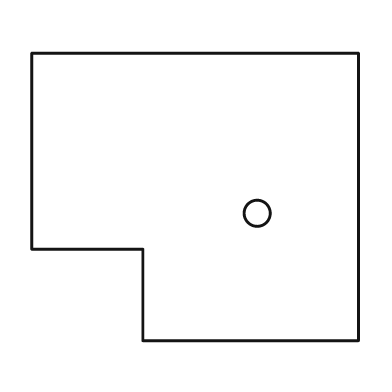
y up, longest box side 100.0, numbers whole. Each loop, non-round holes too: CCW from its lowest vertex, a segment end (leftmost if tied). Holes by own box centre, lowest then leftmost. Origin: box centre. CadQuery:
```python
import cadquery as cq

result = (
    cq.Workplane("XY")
    .moveTo(-16.0, -44.0)
    .lineTo(50.0, -44.0)
    .lineTo(50.0, 44.0)
    .lineTo(-50.0, 44.0)
    .lineTo(-50.0, -16.0)
    .lineTo(-16.0, -16.0)
    .close()
    .moveTo(19.0, -5.0)
    .circle(4.0)
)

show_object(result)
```